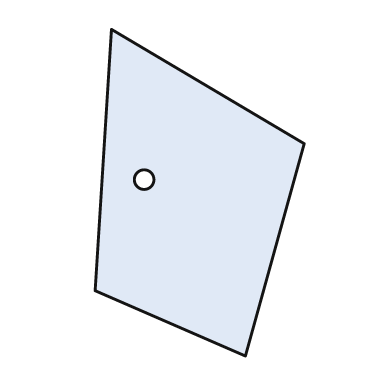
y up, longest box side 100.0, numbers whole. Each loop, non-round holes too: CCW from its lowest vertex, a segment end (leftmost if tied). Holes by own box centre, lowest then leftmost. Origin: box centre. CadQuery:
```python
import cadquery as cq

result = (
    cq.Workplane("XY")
    .moveTo(14.0, -50.0)
    .lineTo(32.0, 15.0)
    .lineTo(-27.0, 50.0)
    .lineTo(-32.0, -30.0)
    .close()
    .moveTo(-17.0, 4.0)
    .circle(3.0)
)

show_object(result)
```